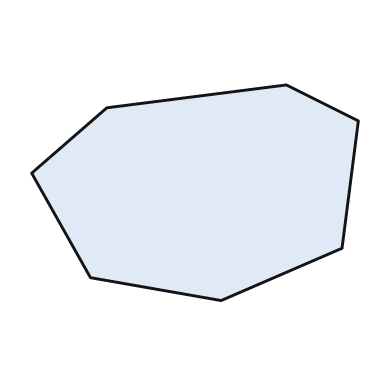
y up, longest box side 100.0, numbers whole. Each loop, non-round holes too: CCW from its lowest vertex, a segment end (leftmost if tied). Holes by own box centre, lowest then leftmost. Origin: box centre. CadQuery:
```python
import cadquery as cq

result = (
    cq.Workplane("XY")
    .moveTo(8.0, -33.0)
    .lineTo(45.0, -17.0)
    .lineTo(50.0, 22.0)
    .lineTo(28.0, 33.0)
    .lineTo(-27.0, 26.0)
    .lineTo(-50.0, 6.0)
    .lineTo(-32.0, -26.0)
    .close()
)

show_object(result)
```